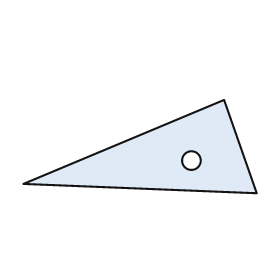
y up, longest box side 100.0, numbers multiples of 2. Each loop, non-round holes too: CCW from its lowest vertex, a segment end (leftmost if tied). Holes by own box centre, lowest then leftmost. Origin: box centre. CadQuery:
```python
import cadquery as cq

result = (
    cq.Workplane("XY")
    .moveTo(50.0, -20.0)
    .lineTo(36.0, 20.0)
    .lineTo(-50.0, -16.0)
    .close()
    .moveTo(22.0, -6.0)
    .circle(4.0)
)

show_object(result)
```